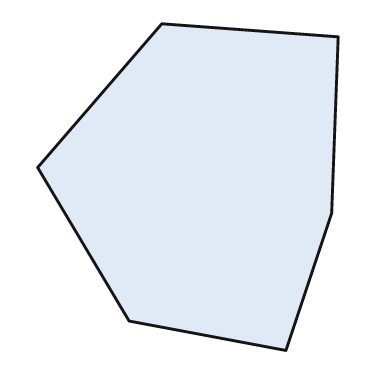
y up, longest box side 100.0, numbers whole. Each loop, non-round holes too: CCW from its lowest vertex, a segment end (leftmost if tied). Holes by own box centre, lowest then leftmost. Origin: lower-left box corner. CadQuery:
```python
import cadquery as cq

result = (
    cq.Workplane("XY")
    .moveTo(76.0, 0.0)
    .lineTo(90.0, 42.0)
    .lineTo(92.0, 96.0)
    .lineTo(38.0, 100.0)
    .lineTo(0.0, 56.0)
    .lineTo(28.0, 9.0)
    .close()
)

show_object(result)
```